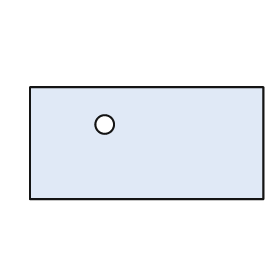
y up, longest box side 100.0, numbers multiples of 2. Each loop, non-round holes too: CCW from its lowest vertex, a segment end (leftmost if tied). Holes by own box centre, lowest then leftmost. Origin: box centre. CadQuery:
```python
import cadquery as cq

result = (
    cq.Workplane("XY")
    .moveTo(-50.0, -24.0)
    .lineTo(50.0, -24.0)
    .lineTo(50.0, 24.0)
    .lineTo(-50.0, 24.0)
    .close()
    .moveTo(-18.0, 8.0)
    .circle(4.0)
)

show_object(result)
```